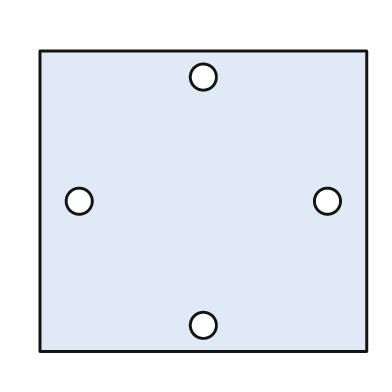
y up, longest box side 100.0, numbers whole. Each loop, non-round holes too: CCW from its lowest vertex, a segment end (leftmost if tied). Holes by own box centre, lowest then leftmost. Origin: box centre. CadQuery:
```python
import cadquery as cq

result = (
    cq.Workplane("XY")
    .moveTo(-50.0, -46.0)
    .lineTo(50.0, -46.0)
    .lineTo(50.0, 46.0)
    .lineTo(-50.0, 46.0)
    .close()
    .moveTo(0.0, -38.0)
    .circle(4.0)
    .moveTo(-38.0, 0.0)
    .circle(4.0)
    .moveTo(38.0, 0.0)
    .circle(4.0)
    .moveTo(0.0, 38.0)
    .circle(4.0)
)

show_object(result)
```